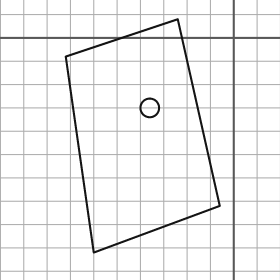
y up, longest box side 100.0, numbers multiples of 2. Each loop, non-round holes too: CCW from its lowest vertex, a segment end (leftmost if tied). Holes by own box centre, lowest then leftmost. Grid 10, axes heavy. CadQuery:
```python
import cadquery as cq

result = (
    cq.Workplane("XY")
    .moveTo(-60.0, -92.0)
    .lineTo(-6.0, -72.0)
    .lineTo(-24.0, 8.0)
    .lineTo(-72.0, -8.0)
    .close()
    .moveTo(-36.0, -30.0)
    .circle(4.0)
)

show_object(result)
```